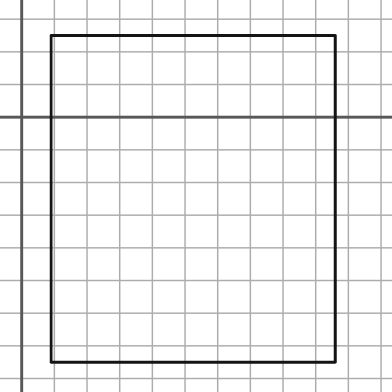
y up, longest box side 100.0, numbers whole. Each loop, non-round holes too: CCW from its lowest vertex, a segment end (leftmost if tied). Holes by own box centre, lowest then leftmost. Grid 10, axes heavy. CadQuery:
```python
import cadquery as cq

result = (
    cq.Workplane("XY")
    .moveTo(9.0, -75.0)
    .lineTo(96.0, -75.0)
    .lineTo(96.0, 25.0)
    .lineTo(9.0, 25.0)
    .close()
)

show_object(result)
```